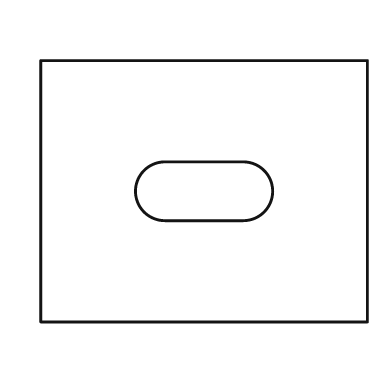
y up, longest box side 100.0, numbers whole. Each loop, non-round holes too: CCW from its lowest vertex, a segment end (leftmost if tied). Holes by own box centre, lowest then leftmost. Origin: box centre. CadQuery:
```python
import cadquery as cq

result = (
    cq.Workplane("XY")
    .moveTo(-50.0, -40.0)
    .lineTo(50.0, -40.0)
    .lineTo(50.0, 40.0)
    .lineTo(-50.0, 40.0)
    .close()
    .moveTo(-12.0, -9.0)
    .lineTo(12.0, -9.0)
    .threePointArc((21.0, 0.0), (12.0, 9.0))
    .lineTo(-12.0, 9.0)
    .threePointArc((-21.0, 0.0), (-12.0, -9.0))
    .close()
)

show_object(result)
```